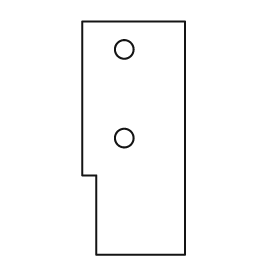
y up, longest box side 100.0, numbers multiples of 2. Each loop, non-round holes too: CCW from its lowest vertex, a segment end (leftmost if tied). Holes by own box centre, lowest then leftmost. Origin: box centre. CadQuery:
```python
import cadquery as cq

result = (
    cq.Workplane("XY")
    .moveTo(-16.0, -50.0)
    .lineTo(22.0, -50.0)
    .lineTo(22.0, 50.0)
    .lineTo(-22.0, 50.0)
    .lineTo(-22.0, -16.0)
    .lineTo(-16.0, -16.0)
    .close()
    .moveTo(-4.0, 0.0)
    .circle(4.0)
    .moveTo(-4.0, 38.0)
    .circle(4.0)
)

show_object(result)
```